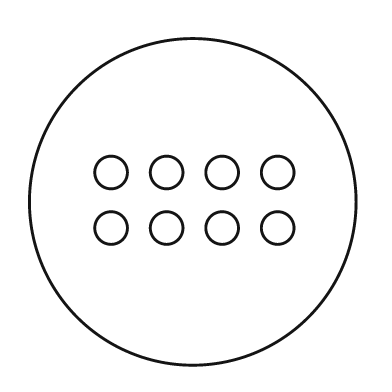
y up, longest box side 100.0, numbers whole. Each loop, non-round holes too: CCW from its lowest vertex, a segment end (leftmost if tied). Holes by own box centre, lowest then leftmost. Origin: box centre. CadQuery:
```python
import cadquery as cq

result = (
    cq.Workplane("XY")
    .moveTo(0.0, 0.0)
    .circle(50.0)
    .moveTo(-25.0, -8.0)
    .circle(5.0)
    .moveTo(-8.0, -8.0)
    .circle(5.0)
    .moveTo(9.0, -8.0)
    .circle(5.0)
    .moveTo(26.0, -8.0)
    .circle(5.0)
    .moveTo(-25.0, 9.0)
    .circle(5.0)
    .moveTo(-8.0, 9.0)
    .circle(5.0)
    .moveTo(9.0, 9.0)
    .circle(5.0)
    .moveTo(26.0, 9.0)
    .circle(5.0)
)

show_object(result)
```